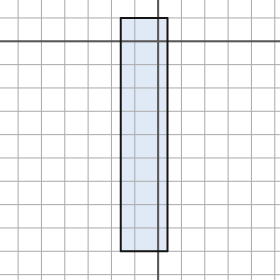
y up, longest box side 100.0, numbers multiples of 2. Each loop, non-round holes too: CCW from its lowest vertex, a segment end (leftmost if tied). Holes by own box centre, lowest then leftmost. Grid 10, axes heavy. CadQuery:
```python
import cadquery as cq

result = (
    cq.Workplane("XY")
    .moveTo(-16.0, -90.0)
    .lineTo(4.0, -90.0)
    .lineTo(4.0, 10.0)
    .lineTo(-16.0, 10.0)
    .close()
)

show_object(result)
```